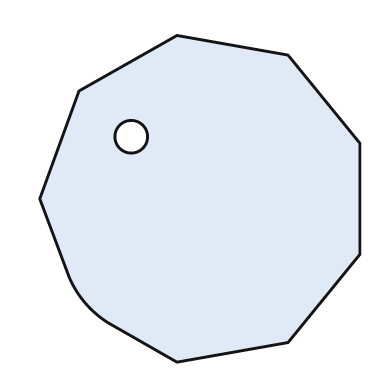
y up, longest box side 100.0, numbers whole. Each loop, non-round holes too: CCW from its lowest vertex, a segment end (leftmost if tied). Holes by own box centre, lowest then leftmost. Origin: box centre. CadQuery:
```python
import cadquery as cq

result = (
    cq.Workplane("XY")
    .moveTo(-7.0, -50.0)
    .lineTo(27.0, -44.0)
    .lineTo(49.0, -17.0)
    .lineTo(49.0, 17.0)
    .lineTo(27.0, 44.0)
    .lineTo(-7.0, 50.0)
    .lineTo(-37.0, 33.0)
    .lineTo(-49.0, 0.0)
    .lineTo(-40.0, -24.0)
    .threePointArc((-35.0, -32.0), (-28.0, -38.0))
    .close()
    .moveTo(-21.0, 19.0)
    .circle(5.0)
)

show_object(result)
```